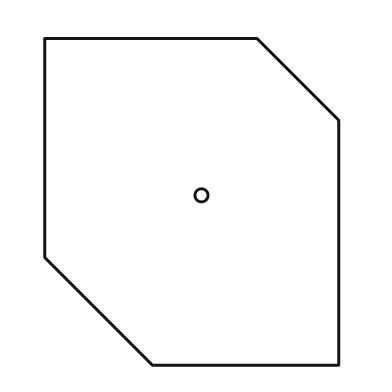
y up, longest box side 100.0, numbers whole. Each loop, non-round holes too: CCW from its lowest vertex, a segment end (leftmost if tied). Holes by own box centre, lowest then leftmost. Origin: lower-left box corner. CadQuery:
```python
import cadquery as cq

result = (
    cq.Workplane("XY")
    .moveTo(33.0, 0.0)
    .lineTo(90.0, 0.0)
    .lineTo(90.0, 75.0)
    .lineTo(65.0, 100.0)
    .lineTo(0.0, 100.0)
    .lineTo(0.0, 33.0)
    .close()
    .moveTo(48.0, 52.0)
    .circle(2.0)
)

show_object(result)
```